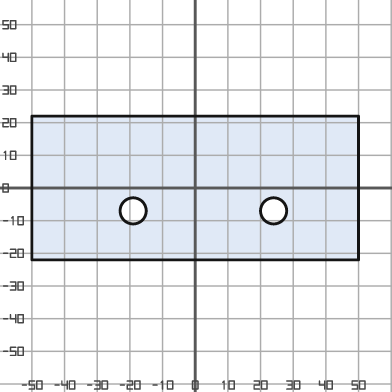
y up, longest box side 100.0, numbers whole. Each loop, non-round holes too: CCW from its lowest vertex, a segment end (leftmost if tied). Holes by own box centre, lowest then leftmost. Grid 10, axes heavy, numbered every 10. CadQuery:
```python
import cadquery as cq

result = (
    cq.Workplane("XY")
    .moveTo(-50.0, -22.0)
    .lineTo(50.0, -22.0)
    .lineTo(50.0, 22.0)
    .lineTo(-50.0, 22.0)
    .close()
    .moveTo(-19.0, -7.0)
    .circle(4.0)
    .moveTo(24.0, -7.0)
    .circle(4.0)
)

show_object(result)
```